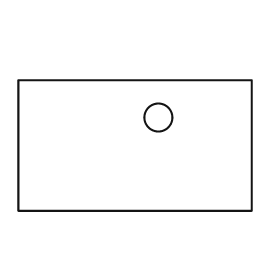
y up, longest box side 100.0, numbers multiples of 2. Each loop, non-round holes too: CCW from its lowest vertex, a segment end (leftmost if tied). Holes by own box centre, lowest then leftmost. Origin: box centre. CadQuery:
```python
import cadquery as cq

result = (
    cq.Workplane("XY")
    .moveTo(-50.0, -28.0)
    .lineTo(50.0, -28.0)
    .lineTo(50.0, 28.0)
    .lineTo(-50.0, 28.0)
    .close()
    .moveTo(10.0, 12.0)
    .circle(6.0)
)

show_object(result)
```